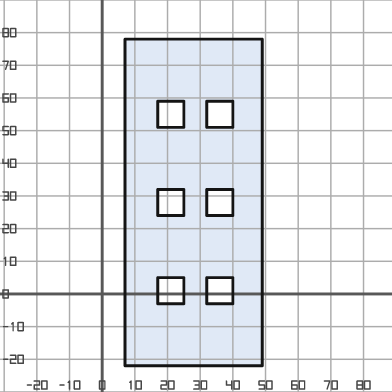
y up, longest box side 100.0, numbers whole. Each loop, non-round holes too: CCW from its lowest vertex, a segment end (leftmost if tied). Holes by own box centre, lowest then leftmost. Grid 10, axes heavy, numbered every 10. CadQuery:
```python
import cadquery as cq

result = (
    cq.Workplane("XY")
    .moveTo(7.0, -22.0)
    .lineTo(49.0, -22.0)
    .lineTo(49.0, 78.0)
    .lineTo(7.0, 78.0)
    .close()
    .moveTo(17.0, -3.0)
    .lineTo(25.0, -3.0)
    .lineTo(25.0, 5.0)
    .lineTo(17.0, 5.0)
    .close()
    .moveTo(32.0, -3.0)
    .lineTo(40.0, -3.0)
    .lineTo(40.0, 5.0)
    .lineTo(32.0, 5.0)
    .close()
    .moveTo(17.0, 24.0)
    .lineTo(25.0, 24.0)
    .lineTo(25.0, 32.0)
    .lineTo(17.0, 32.0)
    .close()
    .moveTo(32.0, 24.0)
    .lineTo(40.0, 24.0)
    .lineTo(40.0, 32.0)
    .lineTo(32.0, 32.0)
    .close()
    .moveTo(17.0, 51.0)
    .lineTo(25.0, 51.0)
    .lineTo(25.0, 59.0)
    .lineTo(17.0, 59.0)
    .close()
    .moveTo(32.0, 51.0)
    .lineTo(40.0, 51.0)
    .lineTo(40.0, 59.0)
    .lineTo(32.0, 59.0)
    .close()
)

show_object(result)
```